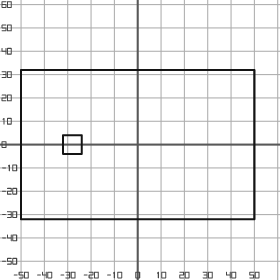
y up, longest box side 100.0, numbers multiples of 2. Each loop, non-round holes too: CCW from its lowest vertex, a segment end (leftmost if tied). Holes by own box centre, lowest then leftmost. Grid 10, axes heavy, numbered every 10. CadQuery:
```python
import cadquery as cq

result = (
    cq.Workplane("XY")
    .moveTo(-50.0, -32.0)
    .lineTo(50.0, -32.0)
    .lineTo(50.0, 32.0)
    .lineTo(-50.0, 32.0)
    .close()
    .moveTo(-32.0, -4.0)
    .lineTo(-24.0, -4.0)
    .lineTo(-24.0, 4.0)
    .lineTo(-32.0, 4.0)
    .close()
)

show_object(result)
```